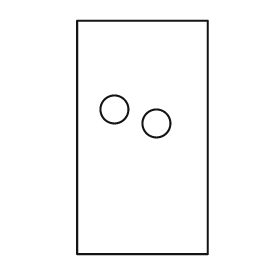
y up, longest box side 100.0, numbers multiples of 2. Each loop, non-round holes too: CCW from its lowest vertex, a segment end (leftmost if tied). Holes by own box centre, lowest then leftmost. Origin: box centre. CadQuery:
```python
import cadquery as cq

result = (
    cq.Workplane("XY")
    .moveTo(-28.0, -50.0)
    .lineTo(28.0, -50.0)
    .lineTo(28.0, 50.0)
    .lineTo(-28.0, 50.0)
    .close()
    .moveTo(6.0, 6.0)
    .circle(6.0)
    .moveTo(-12.0, 12.0)
    .circle(6.0)
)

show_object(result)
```